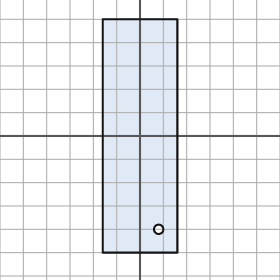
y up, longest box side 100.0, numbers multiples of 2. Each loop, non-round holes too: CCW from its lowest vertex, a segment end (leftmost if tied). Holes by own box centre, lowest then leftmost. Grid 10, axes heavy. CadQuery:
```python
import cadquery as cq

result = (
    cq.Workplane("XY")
    .moveTo(-16.0, -50.0)
    .lineTo(16.0, -50.0)
    .lineTo(16.0, 50.0)
    .lineTo(-16.0, 50.0)
    .close()
    .moveTo(8.0, -40.0)
    .circle(2.0)
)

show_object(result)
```